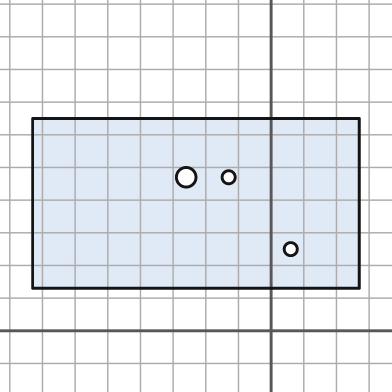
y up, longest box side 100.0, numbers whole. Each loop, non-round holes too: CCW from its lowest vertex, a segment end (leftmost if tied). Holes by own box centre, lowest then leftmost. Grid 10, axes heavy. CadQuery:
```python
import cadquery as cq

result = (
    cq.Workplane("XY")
    .moveTo(-73.0, 13.0)
    .lineTo(27.0, 13.0)
    .lineTo(27.0, 65.0)
    .lineTo(-73.0, 65.0)
    .close()
    .moveTo(6.0, 25.0)
    .circle(2.0)
    .moveTo(-26.0, 47.0)
    .circle(3.0)
    .moveTo(-13.0, 47.0)
    .circle(2.0)
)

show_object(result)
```